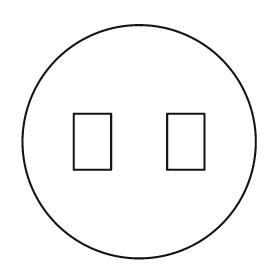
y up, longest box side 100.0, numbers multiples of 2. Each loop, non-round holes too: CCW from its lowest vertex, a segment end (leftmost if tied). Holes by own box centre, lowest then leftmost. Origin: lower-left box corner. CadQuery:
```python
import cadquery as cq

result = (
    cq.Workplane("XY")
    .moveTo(50.0, 50.0)
    .circle(50.0)
    .moveTo(22.0, 38.0)
    .lineTo(38.0, 38.0)
    .lineTo(38.0, 62.0)
    .lineTo(22.0, 62.0)
    .close()
    .moveTo(62.0, 38.0)
    .lineTo(78.0, 38.0)
    .lineTo(78.0, 62.0)
    .lineTo(62.0, 62.0)
    .close()
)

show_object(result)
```